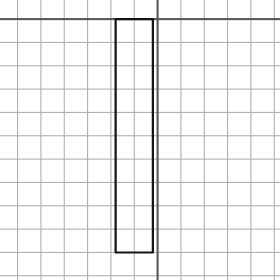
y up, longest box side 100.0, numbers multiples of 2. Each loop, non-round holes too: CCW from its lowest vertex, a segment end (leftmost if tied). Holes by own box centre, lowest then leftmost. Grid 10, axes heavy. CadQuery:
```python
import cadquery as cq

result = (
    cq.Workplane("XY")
    .moveTo(-18.0, -100.0)
    .lineTo(-2.0, -100.0)
    .lineTo(-2.0, 0.0)
    .lineTo(-18.0, 0.0)
    .close()
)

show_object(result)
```